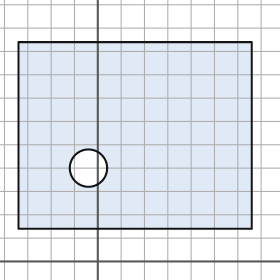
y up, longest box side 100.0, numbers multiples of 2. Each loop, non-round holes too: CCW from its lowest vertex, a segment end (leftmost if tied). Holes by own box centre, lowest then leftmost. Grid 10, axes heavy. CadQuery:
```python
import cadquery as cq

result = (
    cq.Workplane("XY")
    .moveTo(-34.0, 14.0)
    .lineTo(66.0, 14.0)
    .lineTo(66.0, 94.0)
    .lineTo(-34.0, 94.0)
    .close()
    .moveTo(-4.0, 40.0)
    .circle(8.0)
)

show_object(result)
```